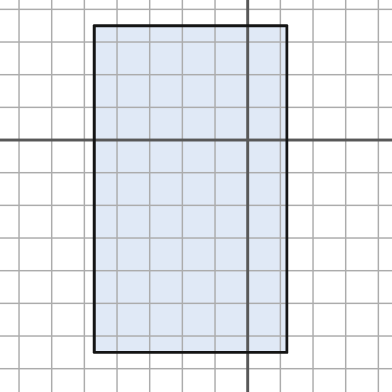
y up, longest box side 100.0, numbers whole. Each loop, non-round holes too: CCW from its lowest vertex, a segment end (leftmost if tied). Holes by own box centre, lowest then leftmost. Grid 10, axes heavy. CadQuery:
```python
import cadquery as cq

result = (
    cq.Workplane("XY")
    .moveTo(-47.0, -65.0)
    .lineTo(12.0, -65.0)
    .lineTo(12.0, 35.0)
    .lineTo(-47.0, 35.0)
    .close()
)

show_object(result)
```